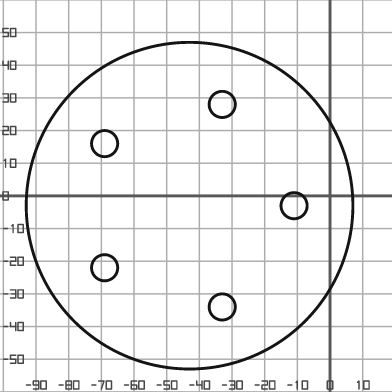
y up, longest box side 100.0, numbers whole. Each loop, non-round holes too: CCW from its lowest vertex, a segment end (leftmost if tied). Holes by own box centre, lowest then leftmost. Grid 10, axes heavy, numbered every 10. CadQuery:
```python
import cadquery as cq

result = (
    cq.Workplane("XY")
    .moveTo(-43.0, -3.0)
    .circle(50.0)
    .moveTo(-33.0, -34.0)
    .circle(4.0)
    .moveTo(-69.0, -22.0)
    .circle(4.0)
    .moveTo(-11.0, -3.0)
    .circle(4.0)
    .moveTo(-69.0, 16.0)
    .circle(4.0)
    .moveTo(-33.0, 28.0)
    .circle(4.0)
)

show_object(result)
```